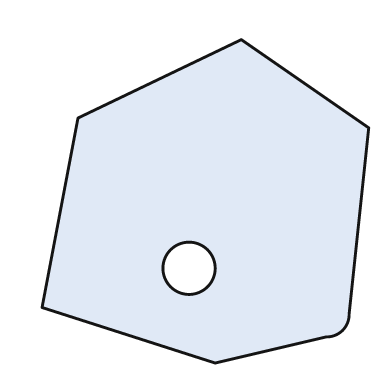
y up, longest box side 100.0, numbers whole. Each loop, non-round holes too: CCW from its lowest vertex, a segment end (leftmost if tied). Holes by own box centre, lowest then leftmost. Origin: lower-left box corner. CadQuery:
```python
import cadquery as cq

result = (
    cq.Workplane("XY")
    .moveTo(53.0, 0.0)
    .lineTo(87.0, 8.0)
    .threePointArc((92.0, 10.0), (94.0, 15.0))
    .lineTo(100.0, 72.0)
    .lineTo(61.0, 99.0)
    .lineTo(11.0, 75.0)
    .lineTo(0.0, 17.0)
    .close()
    .moveTo(45.0, 29.0)
    .circle(8.0)
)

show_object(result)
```